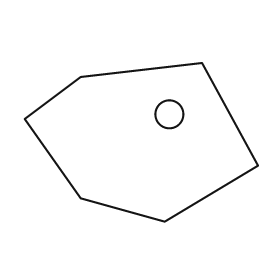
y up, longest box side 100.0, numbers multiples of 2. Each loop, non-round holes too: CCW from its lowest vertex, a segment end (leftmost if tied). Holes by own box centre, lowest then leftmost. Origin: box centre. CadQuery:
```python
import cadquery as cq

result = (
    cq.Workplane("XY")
    .moveTo(10.0, -34.0)
    .lineTo(50.0, -10.0)
    .lineTo(26.0, 34.0)
    .lineTo(-26.0, 28.0)
    .lineTo(-50.0, 10.0)
    .lineTo(-26.0, -24.0)
    .close()
    .moveTo(12.0, 12.0)
    .circle(6.0)
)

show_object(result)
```